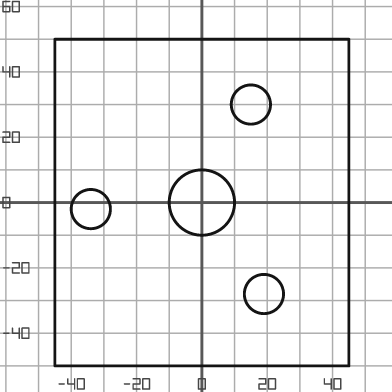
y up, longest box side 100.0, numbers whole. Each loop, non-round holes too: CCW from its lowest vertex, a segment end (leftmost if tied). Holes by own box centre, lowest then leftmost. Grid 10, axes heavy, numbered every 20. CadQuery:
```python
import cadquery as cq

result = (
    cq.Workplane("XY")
    .moveTo(-45.0, -50.0)
    .lineTo(45.0, -50.0)
    .lineTo(45.0, 50.0)
    .lineTo(-45.0, 50.0)
    .close()
    .moveTo(19.0, -28.0)
    .circle(6.0)
    .moveTo(-34.0, -2.0)
    .circle(6.0)
    .moveTo(0.0, 0.0)
    .circle(10.0)
    .moveTo(15.0, 30.0)
    .circle(6.0)
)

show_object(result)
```